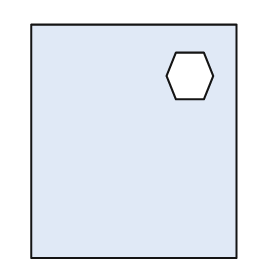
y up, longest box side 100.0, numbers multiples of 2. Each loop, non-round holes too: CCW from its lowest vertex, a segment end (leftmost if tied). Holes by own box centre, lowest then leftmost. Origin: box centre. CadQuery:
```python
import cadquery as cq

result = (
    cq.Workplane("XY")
    .moveTo(-44.0, -50.0)
    .lineTo(44.0, -50.0)
    .lineTo(44.0, 50.0)
    .lineTo(-44.0, 50.0)
    .close()
    .moveTo(18.0, 18.0)
    .lineTo(30.0, 18.0)
    .lineTo(34.0, 28.0)
    .lineTo(30.0, 38.0)
    .lineTo(18.0, 38.0)
    .lineTo(14.0, 28.0)
    .close()
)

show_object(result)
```